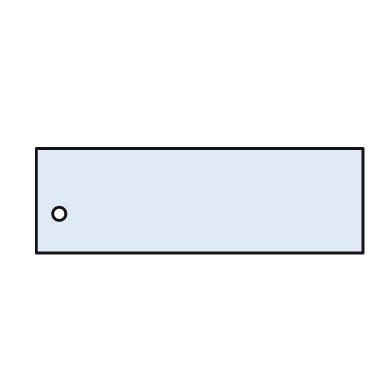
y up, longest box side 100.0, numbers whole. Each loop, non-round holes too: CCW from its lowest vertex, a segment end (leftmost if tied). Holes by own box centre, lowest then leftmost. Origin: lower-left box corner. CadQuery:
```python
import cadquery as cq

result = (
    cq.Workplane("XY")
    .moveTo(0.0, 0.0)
    .lineTo(100.0, 0.0)
    .lineTo(100.0, 32.0)
    .lineTo(0.0, 32.0)
    .close()
    .moveTo(7.0, 12.0)
    .circle(2.0)
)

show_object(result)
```